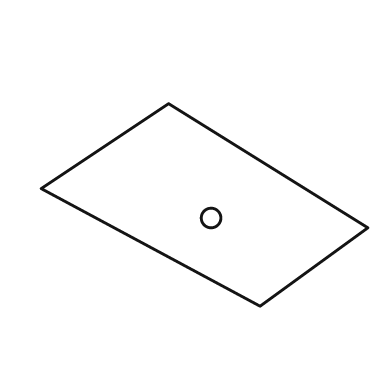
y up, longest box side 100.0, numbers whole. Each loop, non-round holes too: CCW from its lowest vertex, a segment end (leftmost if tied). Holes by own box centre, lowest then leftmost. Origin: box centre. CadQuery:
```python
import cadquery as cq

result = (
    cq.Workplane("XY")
    .moveTo(17.0, -31.0)
    .lineTo(50.0, -7.0)
    .lineTo(-11.0, 31.0)
    .lineTo(-50.0, 5.0)
    .close()
    .moveTo(2.0, -4.0)
    .circle(3.0)
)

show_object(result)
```